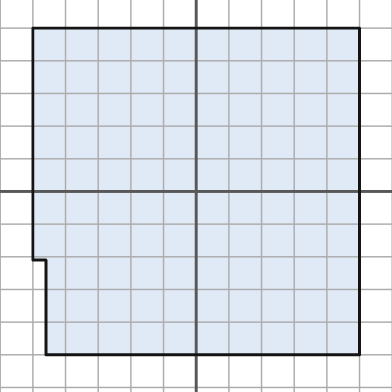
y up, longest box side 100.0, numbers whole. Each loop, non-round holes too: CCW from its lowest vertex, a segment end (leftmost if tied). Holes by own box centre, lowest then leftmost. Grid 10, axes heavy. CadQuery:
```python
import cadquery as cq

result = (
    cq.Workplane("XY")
    .moveTo(-46.0, -50.0)
    .lineTo(50.0, -50.0)
    .lineTo(50.0, 50.0)
    .lineTo(-50.0, 50.0)
    .lineTo(-50.0, -21.0)
    .lineTo(-46.0, -21.0)
    .close()
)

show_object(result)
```